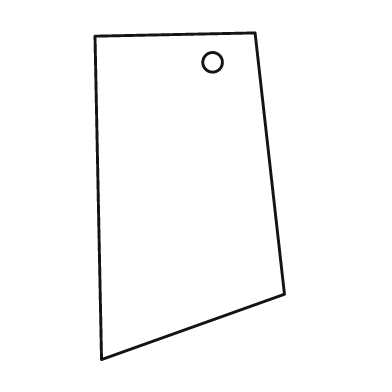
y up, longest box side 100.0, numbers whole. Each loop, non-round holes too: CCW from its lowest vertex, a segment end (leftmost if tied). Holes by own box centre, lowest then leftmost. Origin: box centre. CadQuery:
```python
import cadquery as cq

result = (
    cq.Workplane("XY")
    .moveTo(-27.0, -50.0)
    .lineTo(29.0, -30.0)
    .lineTo(20.0, 50.0)
    .lineTo(-29.0, 49.0)
    .close()
    .moveTo(7.0, 41.0)
    .circle(3.0)
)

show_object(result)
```